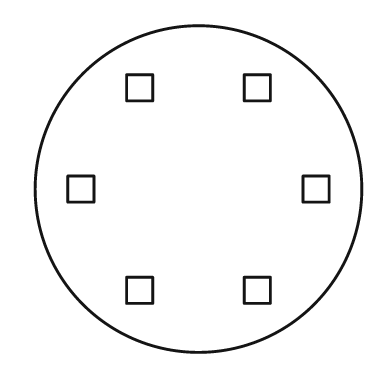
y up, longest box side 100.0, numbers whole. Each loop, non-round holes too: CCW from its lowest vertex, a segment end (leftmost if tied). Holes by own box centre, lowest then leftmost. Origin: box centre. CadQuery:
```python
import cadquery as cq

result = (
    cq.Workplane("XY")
    .moveTo(0.0, 0.0)
    .circle(50.0)
    .moveTo(-22.0, -35.0)
    .lineTo(-14.0, -35.0)
    .lineTo(-14.0, -27.0)
    .lineTo(-22.0, -27.0)
    .close()
    .moveTo(14.0, -35.0)
    .lineTo(22.0, -35.0)
    .lineTo(22.0, -27.0)
    .lineTo(14.0, -27.0)
    .close()
    .moveTo(-40.0, -4.0)
    .lineTo(-32.0, -4.0)
    .lineTo(-32.0, 4.0)
    .lineTo(-40.0, 4.0)
    .close()
    .moveTo(32.0, -4.0)
    .lineTo(40.0, -4.0)
    .lineTo(40.0, 4.0)
    .lineTo(32.0, 4.0)
    .close()
    .moveTo(-22.0, 27.0)
    .lineTo(-14.0, 27.0)
    .lineTo(-14.0, 35.0)
    .lineTo(-22.0, 35.0)
    .close()
    .moveTo(14.0, 27.0)
    .lineTo(22.0, 27.0)
    .lineTo(22.0, 35.0)
    .lineTo(14.0, 35.0)
    .close()
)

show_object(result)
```